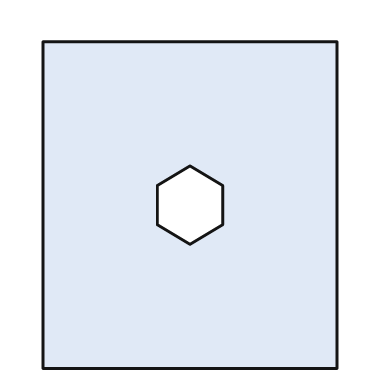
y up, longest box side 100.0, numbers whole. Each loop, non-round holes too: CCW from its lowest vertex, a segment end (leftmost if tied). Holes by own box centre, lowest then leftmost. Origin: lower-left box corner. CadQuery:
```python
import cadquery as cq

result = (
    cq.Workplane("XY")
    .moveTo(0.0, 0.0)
    .lineTo(90.0, 0.0)
    .lineTo(90.0, 100.0)
    .lineTo(0.0, 100.0)
    .close()
    .moveTo(45.0, 38.0)
    .lineTo(55.0, 44.0)
    .lineTo(55.0, 56.0)
    .lineTo(45.0, 62.0)
    .lineTo(35.0, 56.0)
    .lineTo(35.0, 44.0)
    .close()
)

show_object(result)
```